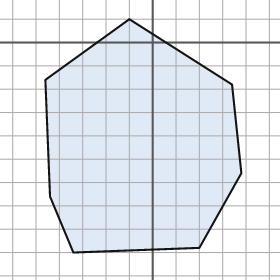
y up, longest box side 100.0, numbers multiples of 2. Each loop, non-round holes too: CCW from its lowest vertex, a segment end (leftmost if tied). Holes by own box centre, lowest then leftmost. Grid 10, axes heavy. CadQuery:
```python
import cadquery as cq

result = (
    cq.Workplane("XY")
    .moveTo(-34.0, -90.0)
    .lineTo(20.0, -88.0)
    .lineTo(38.0, -56.0)
    .lineTo(34.0, -18.0)
    .lineTo(-10.0, 10.0)
    .lineTo(-46.0, -16.0)
    .lineTo(-44.0, -66.0)
    .close()
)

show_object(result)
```